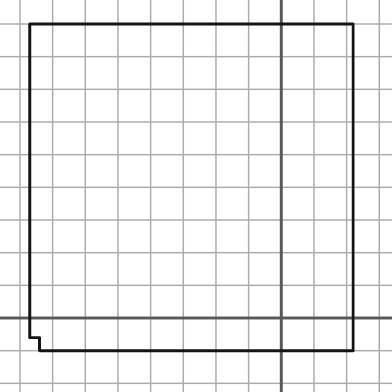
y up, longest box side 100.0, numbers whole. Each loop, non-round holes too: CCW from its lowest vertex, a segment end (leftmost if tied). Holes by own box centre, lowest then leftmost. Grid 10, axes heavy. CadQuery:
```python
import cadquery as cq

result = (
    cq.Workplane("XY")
    .moveTo(-74.0, -10.0)
    .lineTo(22.0, -10.0)
    .lineTo(22.0, 90.0)
    .lineTo(-77.0, 90.0)
    .lineTo(-77.0, -6.0)
    .lineTo(-74.0, -6.0)
    .close()
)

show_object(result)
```